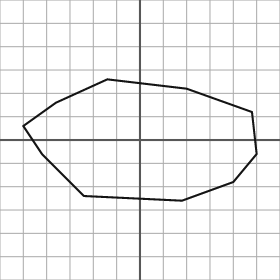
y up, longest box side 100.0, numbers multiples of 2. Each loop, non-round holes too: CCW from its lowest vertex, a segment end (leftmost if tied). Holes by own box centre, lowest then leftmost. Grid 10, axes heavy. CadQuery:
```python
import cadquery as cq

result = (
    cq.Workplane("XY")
    .moveTo(18.0, -26.0)
    .lineTo(40.0, -18.0)
    .lineTo(50.0, -6.0)
    .lineTo(48.0, 12.0)
    .lineTo(20.0, 22.0)
    .lineTo(-14.0, 26.0)
    .lineTo(-36.0, 16.0)
    .lineTo(-50.0, 6.0)
    .lineTo(-42.0, -6.0)
    .lineTo(-24.0, -24.0)
    .close()
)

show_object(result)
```